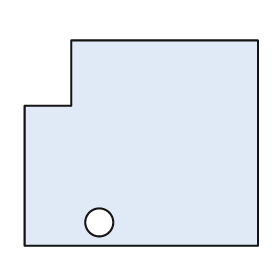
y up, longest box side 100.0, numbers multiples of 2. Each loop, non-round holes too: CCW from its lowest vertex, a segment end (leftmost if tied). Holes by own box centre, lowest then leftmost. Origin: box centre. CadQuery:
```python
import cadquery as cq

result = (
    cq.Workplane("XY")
    .moveTo(-50.0, -44.0)
    .lineTo(50.0, -44.0)
    .lineTo(50.0, 44.0)
    .lineTo(-30.0, 44.0)
    .lineTo(-30.0, 16.0)
    .lineTo(-50.0, 16.0)
    .close()
    .moveTo(-18.0, -34.0)
    .circle(6.0)
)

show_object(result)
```